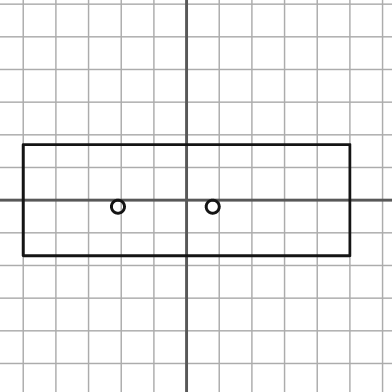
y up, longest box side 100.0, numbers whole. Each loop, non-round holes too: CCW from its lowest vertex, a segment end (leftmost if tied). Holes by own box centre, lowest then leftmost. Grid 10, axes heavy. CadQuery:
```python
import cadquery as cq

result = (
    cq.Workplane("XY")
    .moveTo(-50.0, -17.0)
    .lineTo(50.0, -17.0)
    .lineTo(50.0, 17.0)
    .lineTo(-50.0, 17.0)
    .close()
    .moveTo(-21.0, -2.0)
    .circle(2.0)
    .moveTo(8.0, -2.0)
    .circle(2.0)
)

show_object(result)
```